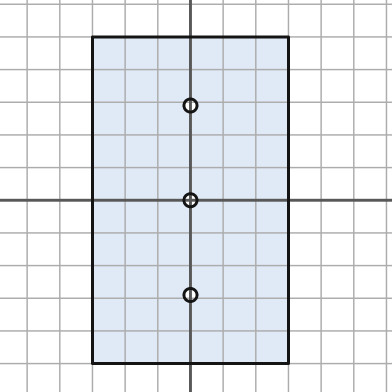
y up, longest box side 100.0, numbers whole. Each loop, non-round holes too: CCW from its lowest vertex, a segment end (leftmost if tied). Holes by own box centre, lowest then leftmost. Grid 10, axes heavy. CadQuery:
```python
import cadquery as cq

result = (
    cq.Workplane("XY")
    .moveTo(-30.0, -50.0)
    .lineTo(30.0, -50.0)
    .lineTo(30.0, 50.0)
    .lineTo(-30.0, 50.0)
    .close()
    .moveTo(0.0, -29.0)
    .circle(2.0)
    .moveTo(0.0, 0.0)
    .circle(2.0)
    .moveTo(0.0, 29.0)
    .circle(2.0)
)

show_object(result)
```